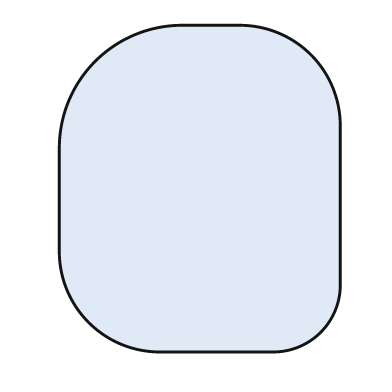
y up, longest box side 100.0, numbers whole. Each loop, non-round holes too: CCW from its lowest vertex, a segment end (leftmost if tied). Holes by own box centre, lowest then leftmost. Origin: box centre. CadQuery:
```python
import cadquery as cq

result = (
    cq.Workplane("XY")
    .moveTo(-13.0, -50.0)
    .lineTo(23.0, -50.0)
    .threePointArc((37.0, -44.0), (43.0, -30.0))
    .lineTo(43.0, 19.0)
    .threePointArc((34.0, 41.0), (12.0, 50.0))
    .lineTo(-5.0, 50.0)
    .threePointArc((-32.0, 39.0), (-43.0, 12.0))
    .lineTo(-43.0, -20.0)
    .threePointArc((-34.0, -41.0), (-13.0, -50.0))
    .close()
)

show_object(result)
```